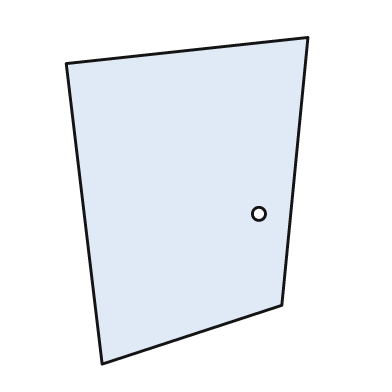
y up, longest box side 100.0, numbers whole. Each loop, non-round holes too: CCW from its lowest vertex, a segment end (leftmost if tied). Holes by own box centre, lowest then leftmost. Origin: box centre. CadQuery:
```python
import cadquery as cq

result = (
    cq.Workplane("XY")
    .moveTo(-26.0, -50.0)
    .lineTo(29.0, -32.0)
    .lineTo(37.0, 50.0)
    .lineTo(-37.0, 42.0)
    .close()
    .moveTo(22.0, -4.0)
    .circle(2.0)
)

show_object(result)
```